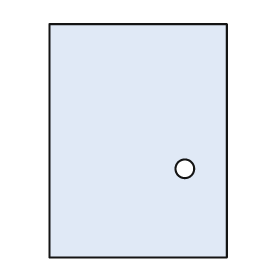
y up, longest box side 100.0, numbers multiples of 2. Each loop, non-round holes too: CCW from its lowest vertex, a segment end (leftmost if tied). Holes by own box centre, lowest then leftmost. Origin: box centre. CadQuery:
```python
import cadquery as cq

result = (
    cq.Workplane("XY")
    .moveTo(-38.0, -50.0)
    .lineTo(38.0, -50.0)
    .lineTo(38.0, 50.0)
    .lineTo(-38.0, 50.0)
    .close()
    .moveTo(20.0, -12.0)
    .circle(4.0)
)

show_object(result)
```